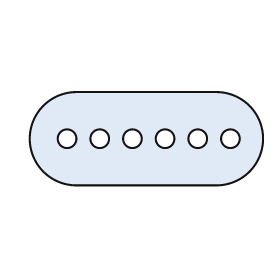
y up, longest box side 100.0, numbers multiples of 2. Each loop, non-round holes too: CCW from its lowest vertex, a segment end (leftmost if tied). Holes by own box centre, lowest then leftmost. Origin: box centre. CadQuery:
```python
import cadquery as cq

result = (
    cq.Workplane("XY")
    .moveTo(-30.0, -20.0)
    .lineTo(30.0, -20.0)
    .threePointArc((50.0, 0.0), (30.0, 20.0))
    .lineTo(-30.0, 20.0)
    .threePointArc((-50.0, 0.0), (-30.0, -20.0))
    .close()
    .moveTo(-34.0, 0.0)
    .circle(4.0)
    .moveTo(-20.0, 0.0)
    .circle(4.0)
    .moveTo(-6.0, 0.0)
    .circle(4.0)
    .moveTo(8.0, 0.0)
    .circle(4.0)
    .moveTo(22.0, 0.0)
    .circle(4.0)
    .moveTo(36.0, 0.0)
    .circle(4.0)
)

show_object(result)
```